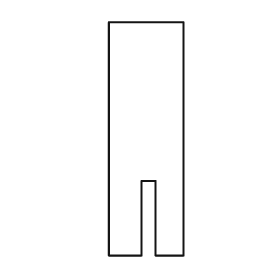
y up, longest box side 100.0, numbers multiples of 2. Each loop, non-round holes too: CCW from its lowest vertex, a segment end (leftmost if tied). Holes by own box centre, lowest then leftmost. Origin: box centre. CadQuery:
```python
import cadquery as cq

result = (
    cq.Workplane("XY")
    .moveTo(-16.0, -50.0)
    .lineTo(-2.0, -50.0)
    .lineTo(-2.0, -18.0)
    .lineTo(4.0, -18.0)
    .lineTo(4.0, -50.0)
    .lineTo(16.0, -50.0)
    .lineTo(16.0, 50.0)
    .lineTo(-16.0, 50.0)
    .close()
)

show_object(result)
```